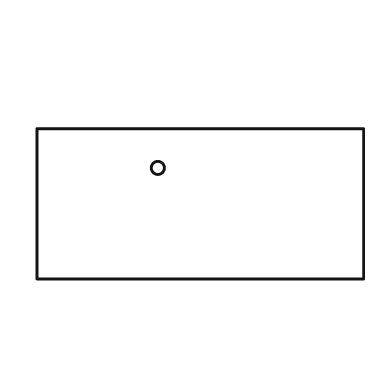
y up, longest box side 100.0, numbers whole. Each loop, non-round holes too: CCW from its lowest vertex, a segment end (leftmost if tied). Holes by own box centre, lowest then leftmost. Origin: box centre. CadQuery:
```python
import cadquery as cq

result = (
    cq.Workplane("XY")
    .moveTo(-50.0, -23.0)
    .lineTo(50.0, -23.0)
    .lineTo(50.0, 23.0)
    .lineTo(-50.0, 23.0)
    .close()
    .moveTo(-13.0, 11.0)
    .circle(2.0)
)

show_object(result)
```